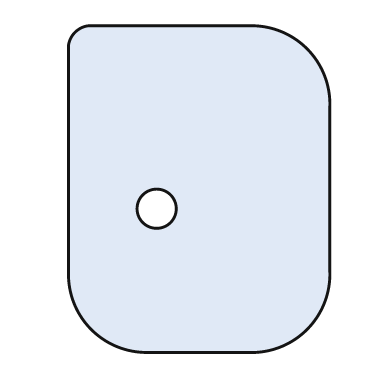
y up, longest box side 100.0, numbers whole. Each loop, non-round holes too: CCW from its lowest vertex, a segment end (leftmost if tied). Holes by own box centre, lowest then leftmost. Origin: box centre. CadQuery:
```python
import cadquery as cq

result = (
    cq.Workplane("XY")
    .moveTo(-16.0, -50.0)
    .lineTo(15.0, -50.0)
    .threePointArc((33.0, -43.0), (40.0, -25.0))
    .lineTo(40.0, 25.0)
    .threePointArc((33.0, 43.0), (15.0, 50.0))
    .lineTo(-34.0, 50.0)
    .threePointArc((-38.0, 48.0), (-40.0, 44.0))
    .lineTo(-40.0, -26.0)
    .threePointArc((-33.0, -43.0), (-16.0, -50.0))
    .close()
    .moveTo(-13.0, -6.0)
    .circle(6.0)
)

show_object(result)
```